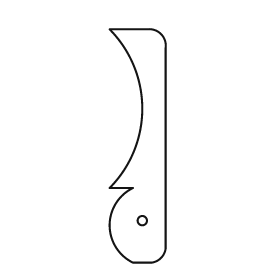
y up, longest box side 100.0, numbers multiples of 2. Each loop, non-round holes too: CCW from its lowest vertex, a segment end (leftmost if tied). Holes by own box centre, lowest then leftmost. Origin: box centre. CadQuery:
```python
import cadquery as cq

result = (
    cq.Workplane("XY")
    .moveTo(-2.0, -50.0)
    .lineTo(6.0, -50.0)
    .threePointArc((10.0, -48.0), (12.0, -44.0))
    .lineTo(12.0, 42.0)
    .threePointArc((10.0, 48.0), (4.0, 50.0))
    .lineTo(-12.0, 50.0)
    .threePointArc((2.0, 16.0), (-12.0, -18.0))
    .lineTo(-2.0, -18.0)
    .threePointArc((-12.0, -34.0), (-2.0, -50.0))
    .close()
    .moveTo(2.0, -32.0)
    .circle(2.0)
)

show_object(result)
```